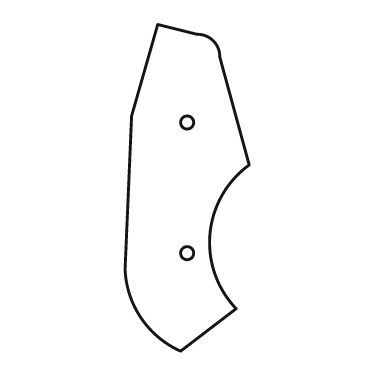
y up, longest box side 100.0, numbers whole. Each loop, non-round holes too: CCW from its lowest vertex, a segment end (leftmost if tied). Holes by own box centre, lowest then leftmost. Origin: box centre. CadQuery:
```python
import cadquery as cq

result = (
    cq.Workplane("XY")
    .moveTo(-2.0, -50.0)
    .lineTo(15.0, -37.0)
    .threePointArc((7.0, -14.0), (19.0, 7.0))
    .lineTo(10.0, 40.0)
    .threePointArc((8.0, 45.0), (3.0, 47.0))
    .lineTo(-9.0, 50.0)
    .lineTo(-17.0, 22.0)
    .lineTo(-19.0, -25.0)
    .threePointArc((-14.0, -40.0), (-2.0, -50.0))
    .close()
    .moveTo(0.0, -20.0)
    .circle(2.0)
    .moveTo(0.0, 20.0)
    .circle(2.0)
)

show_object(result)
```